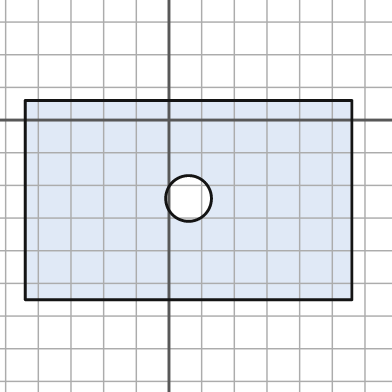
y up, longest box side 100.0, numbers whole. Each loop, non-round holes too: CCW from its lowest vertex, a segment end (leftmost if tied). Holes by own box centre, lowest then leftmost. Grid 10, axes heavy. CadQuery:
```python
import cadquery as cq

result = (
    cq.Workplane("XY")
    .moveTo(-44.0, -55.0)
    .lineTo(56.0, -55.0)
    .lineTo(56.0, 6.0)
    .lineTo(-44.0, 6.0)
    .close()
    .moveTo(6.0, -24.0)
    .circle(7.0)
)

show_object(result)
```